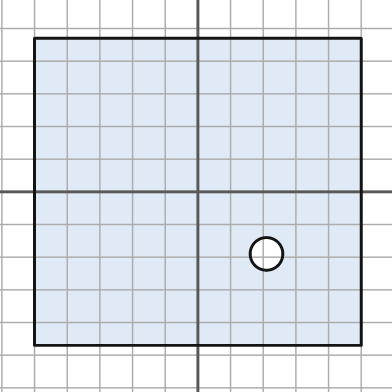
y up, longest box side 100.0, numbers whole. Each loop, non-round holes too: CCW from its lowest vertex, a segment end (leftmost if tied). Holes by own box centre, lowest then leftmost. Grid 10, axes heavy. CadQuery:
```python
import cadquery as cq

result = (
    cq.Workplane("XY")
    .moveTo(-50.0, -47.0)
    .lineTo(50.0, -47.0)
    .lineTo(50.0, 47.0)
    .lineTo(-50.0, 47.0)
    .close()
    .moveTo(21.0, -19.0)
    .circle(5.0)
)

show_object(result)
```